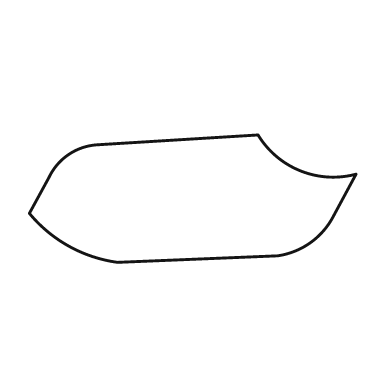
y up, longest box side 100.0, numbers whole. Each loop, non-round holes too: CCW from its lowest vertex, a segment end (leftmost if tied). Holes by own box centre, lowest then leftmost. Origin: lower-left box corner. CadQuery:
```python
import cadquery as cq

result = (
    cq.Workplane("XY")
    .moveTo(27.0, 0.0)
    .lineTo(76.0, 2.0)
    .threePointArc((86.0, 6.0), (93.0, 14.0))
    .lineTo(100.0, 27.0)
    .threePointArc((83.0, 28.0), (70.0, 39.0))
    .lineTo(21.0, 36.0)
    .threePointArc((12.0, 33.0), (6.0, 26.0))
    .lineTo(0.0, 15.0)
    .threePointArc((12.0, 5.0), (27.0, 0.0))
    .close()
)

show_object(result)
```